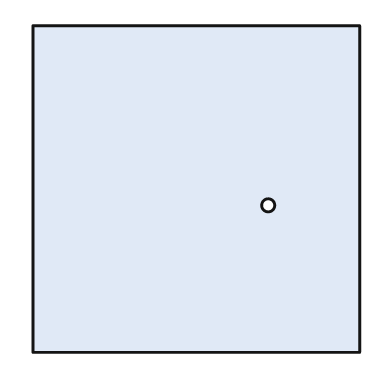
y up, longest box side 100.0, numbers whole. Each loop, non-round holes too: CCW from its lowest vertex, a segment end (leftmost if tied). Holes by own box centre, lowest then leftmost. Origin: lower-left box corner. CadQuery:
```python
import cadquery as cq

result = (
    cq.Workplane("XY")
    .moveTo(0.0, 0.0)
    .lineTo(100.0, 0.0)
    .lineTo(100.0, 100.0)
    .lineTo(0.0, 100.0)
    .close()
    .moveTo(72.0, 45.0)
    .circle(2.0)
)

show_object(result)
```